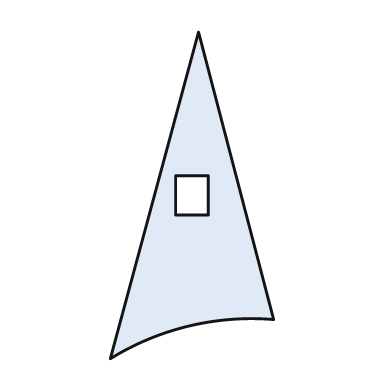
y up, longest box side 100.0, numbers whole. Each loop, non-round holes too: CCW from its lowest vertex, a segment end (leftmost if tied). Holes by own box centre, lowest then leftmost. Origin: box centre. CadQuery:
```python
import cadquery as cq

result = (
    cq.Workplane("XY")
    .moveTo(-25.0, -50.0)
    .threePointArc((-1.0, -40.0), (25.0, -38.0))
    .lineTo(2.0, 50.0)
    .close()
    .moveTo(-5.0, -6.0)
    .lineTo(5.0, -6.0)
    .lineTo(5.0, 6.0)
    .lineTo(-5.0, 6.0)
    .close()
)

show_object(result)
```